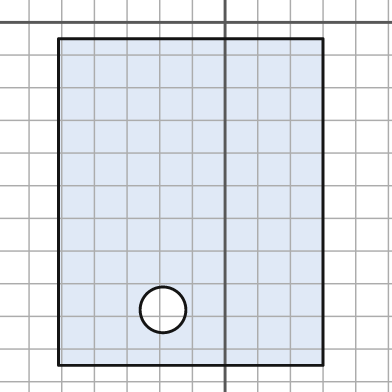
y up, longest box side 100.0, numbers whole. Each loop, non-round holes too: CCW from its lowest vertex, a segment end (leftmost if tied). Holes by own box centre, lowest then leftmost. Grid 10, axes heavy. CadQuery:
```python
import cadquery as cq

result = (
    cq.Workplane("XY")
    .moveTo(-51.0, -105.0)
    .lineTo(30.0, -105.0)
    .lineTo(30.0, -5.0)
    .lineTo(-51.0, -5.0)
    .close()
    .moveTo(-19.0, -88.0)
    .circle(7.0)
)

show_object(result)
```